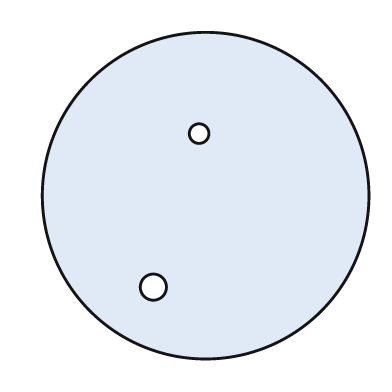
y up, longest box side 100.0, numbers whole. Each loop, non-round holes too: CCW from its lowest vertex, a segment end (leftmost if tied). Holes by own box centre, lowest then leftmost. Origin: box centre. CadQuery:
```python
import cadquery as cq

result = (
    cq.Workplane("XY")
    .moveTo(0.0, 0.0)
    .circle(50.0)
    .moveTo(-16.0, -28.0)
    .circle(4.0)
    .moveTo(-2.0, 19.0)
    .circle(3.0)
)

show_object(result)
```